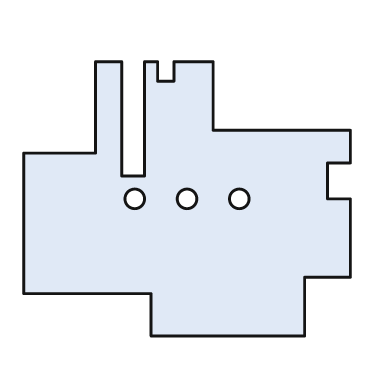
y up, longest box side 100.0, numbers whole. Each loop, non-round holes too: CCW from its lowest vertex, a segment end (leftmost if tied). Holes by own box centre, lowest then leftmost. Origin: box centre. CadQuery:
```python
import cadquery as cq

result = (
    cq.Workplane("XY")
    .moveTo(-11.0, -42.0)
    .lineTo(36.0, -42.0)
    .lineTo(36.0, -24.0)
    .lineTo(50.0, -24.0)
    .lineTo(50.0, 0.0)
    .lineTo(43.0, 0.0)
    .lineTo(43.0, 11.0)
    .lineTo(50.0, 11.0)
    .lineTo(50.0, 21.0)
    .lineTo(8.0, 21.0)
    .lineTo(8.0, 42.0)
    .lineTo(-4.0, 42.0)
    .lineTo(-4.0, 36.0)
    .lineTo(-9.0, 36.0)
    .lineTo(-9.0, 42.0)
    .lineTo(-13.0, 42.0)
    .lineTo(-13.0, 7.0)
    .lineTo(-20.0, 7.0)
    .lineTo(-20.0, 42.0)
    .lineTo(-28.0, 42.0)
    .lineTo(-28.0, 14.0)
    .lineTo(-50.0, 14.0)
    .lineTo(-50.0, -29.0)
    .lineTo(-11.0, -29.0)
    .close()
    .moveTo(-16.0, 0.0)
    .circle(3.0)
    .moveTo(0.0, 0.0)
    .circle(3.0)
    .moveTo(16.0, 0.0)
    .circle(3.0)
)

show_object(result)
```